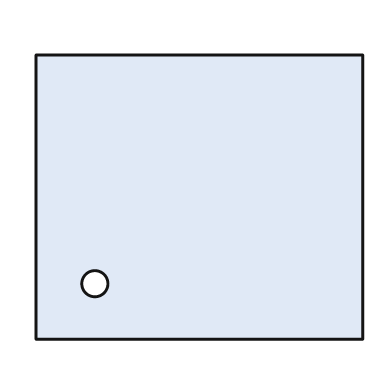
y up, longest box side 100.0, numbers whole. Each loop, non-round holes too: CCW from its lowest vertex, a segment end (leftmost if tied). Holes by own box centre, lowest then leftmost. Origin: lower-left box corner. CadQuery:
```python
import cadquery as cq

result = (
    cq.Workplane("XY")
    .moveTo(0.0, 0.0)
    .lineTo(100.0, 0.0)
    .lineTo(100.0, 87.0)
    .lineTo(0.0, 87.0)
    .close()
    .moveTo(18.0, 17.0)
    .circle(4.0)
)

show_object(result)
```